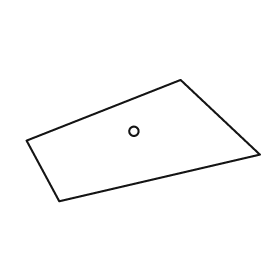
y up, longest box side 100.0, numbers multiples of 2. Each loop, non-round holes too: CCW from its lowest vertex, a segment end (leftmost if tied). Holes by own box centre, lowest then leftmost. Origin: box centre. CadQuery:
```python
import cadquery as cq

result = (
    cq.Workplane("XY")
    .moveTo(-36.0, -26.0)
    .lineTo(50.0, -6.0)
    .lineTo(16.0, 26.0)
    .lineTo(-50.0, 0.0)
    .close()
    .moveTo(-4.0, 4.0)
    .circle(2.0)
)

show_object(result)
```